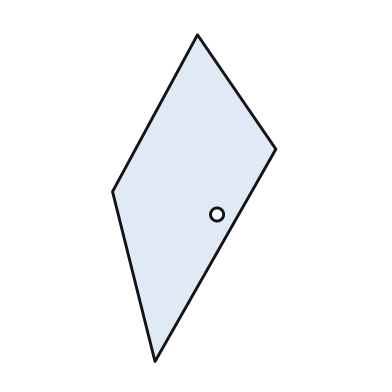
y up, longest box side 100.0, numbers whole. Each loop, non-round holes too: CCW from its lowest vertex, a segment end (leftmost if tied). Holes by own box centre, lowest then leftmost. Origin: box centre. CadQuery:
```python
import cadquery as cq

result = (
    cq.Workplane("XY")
    .moveTo(-12.0, -50.0)
    .lineTo(25.0, 15.0)
    .lineTo(1.0, 50.0)
    .lineTo(-25.0, 2.0)
    .close()
    .moveTo(7.0, -5.0)
    .circle(2.0)
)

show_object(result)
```